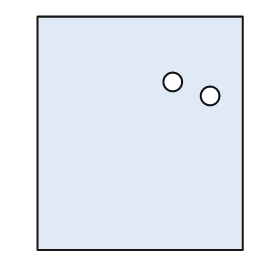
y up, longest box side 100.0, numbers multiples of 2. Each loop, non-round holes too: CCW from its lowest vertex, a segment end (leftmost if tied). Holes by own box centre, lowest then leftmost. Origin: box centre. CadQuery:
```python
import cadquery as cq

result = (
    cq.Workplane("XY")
    .moveTo(-44.0, -50.0)
    .lineTo(44.0, -50.0)
    .lineTo(44.0, 50.0)
    .lineTo(-44.0, 50.0)
    .close()
    .moveTo(30.0, 16.0)
    .circle(4.0)
    .moveTo(14.0, 22.0)
    .circle(4.0)
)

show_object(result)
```